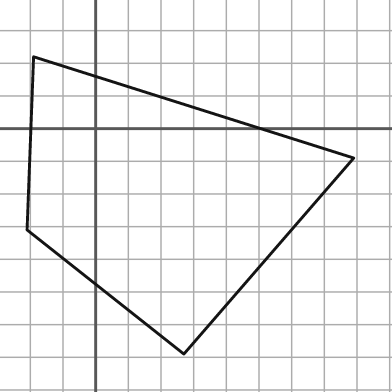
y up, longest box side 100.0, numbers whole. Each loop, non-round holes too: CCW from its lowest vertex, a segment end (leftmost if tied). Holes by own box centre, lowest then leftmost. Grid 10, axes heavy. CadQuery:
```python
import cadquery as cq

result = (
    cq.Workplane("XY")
    .moveTo(27.0, -69.0)
    .lineTo(79.0, -9.0)
    .lineTo(-19.0, 22.0)
    .lineTo(-21.0, -31.0)
    .close()
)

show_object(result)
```